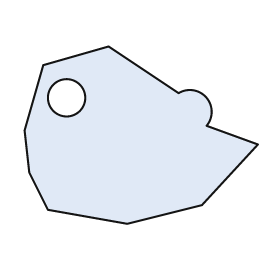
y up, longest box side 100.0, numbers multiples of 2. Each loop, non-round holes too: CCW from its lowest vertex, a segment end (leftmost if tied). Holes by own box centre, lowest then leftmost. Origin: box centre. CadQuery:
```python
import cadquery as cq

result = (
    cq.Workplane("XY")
    .moveTo(-6.0, -38.0)
    .lineTo(26.0, -30.0)
    .lineTo(50.0, -4.0)
    .lineTo(28.0, 4.0)
    .threePointArc((28.0, 16.0), (16.0, 18.0))
    .lineTo(-14.0, 38.0)
    .lineTo(-42.0, 30.0)
    .lineTo(-50.0, 2.0)
    .lineTo(-48.0, -16.0)
    .lineTo(-40.0, -32.0)
    .close()
    .moveTo(-32.0, 16.0)
    .circle(8.0)
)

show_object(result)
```